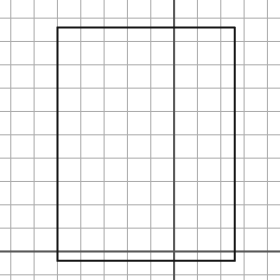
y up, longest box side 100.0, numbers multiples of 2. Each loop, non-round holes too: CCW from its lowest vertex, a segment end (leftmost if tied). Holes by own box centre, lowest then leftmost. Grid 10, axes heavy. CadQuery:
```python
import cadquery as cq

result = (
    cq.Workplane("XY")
    .moveTo(-50.0, -4.0)
    .lineTo(26.0, -4.0)
    .lineTo(26.0, 96.0)
    .lineTo(-50.0, 96.0)
    .close()
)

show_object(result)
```